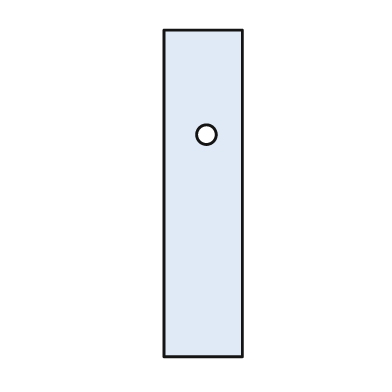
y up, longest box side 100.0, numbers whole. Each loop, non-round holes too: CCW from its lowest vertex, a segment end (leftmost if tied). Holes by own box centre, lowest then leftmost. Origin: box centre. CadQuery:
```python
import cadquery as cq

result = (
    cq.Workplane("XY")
    .moveTo(-12.0, -50.0)
    .lineTo(12.0, -50.0)
    .lineTo(12.0, 50.0)
    .lineTo(-12.0, 50.0)
    .close()
    .moveTo(1.0, 18.0)
    .circle(3.0)
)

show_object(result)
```